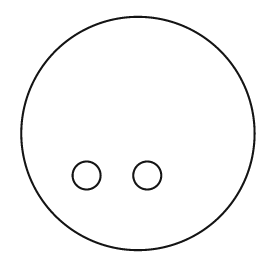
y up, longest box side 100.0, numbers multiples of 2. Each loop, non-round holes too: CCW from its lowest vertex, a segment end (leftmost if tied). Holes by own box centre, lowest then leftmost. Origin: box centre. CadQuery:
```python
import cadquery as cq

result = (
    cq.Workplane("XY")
    .moveTo(0.0, 0.0)
    .circle(50.0)
    .moveTo(-22.0, -18.0)
    .circle(6.0)
    .moveTo(4.0, -18.0)
    .circle(6.0)
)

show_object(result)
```